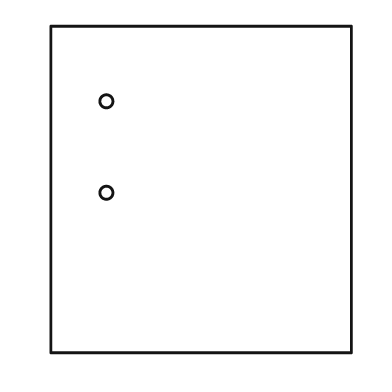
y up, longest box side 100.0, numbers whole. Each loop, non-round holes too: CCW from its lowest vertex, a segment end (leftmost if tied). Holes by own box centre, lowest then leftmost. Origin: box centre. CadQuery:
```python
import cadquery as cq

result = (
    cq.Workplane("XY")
    .moveTo(-46.0, -50.0)
    .lineTo(46.0, -50.0)
    .lineTo(46.0, 50.0)
    .lineTo(-46.0, 50.0)
    .close()
    .moveTo(-29.0, -1.0)
    .circle(2.0)
    .moveTo(-29.0, 27.0)
    .circle(2.0)
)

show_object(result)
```